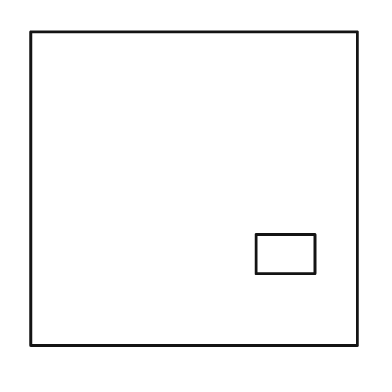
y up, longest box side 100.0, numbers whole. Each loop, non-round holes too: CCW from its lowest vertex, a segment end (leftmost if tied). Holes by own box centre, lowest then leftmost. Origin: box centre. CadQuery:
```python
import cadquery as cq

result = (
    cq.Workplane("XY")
    .moveTo(-50.0, -48.0)
    .lineTo(50.0, -48.0)
    .lineTo(50.0, 48.0)
    .lineTo(-50.0, 48.0)
    .close()
    .moveTo(19.0, -26.0)
    .lineTo(37.0, -26.0)
    .lineTo(37.0, -14.0)
    .lineTo(19.0, -14.0)
    .close()
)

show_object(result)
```